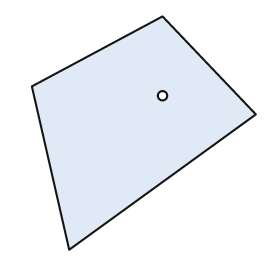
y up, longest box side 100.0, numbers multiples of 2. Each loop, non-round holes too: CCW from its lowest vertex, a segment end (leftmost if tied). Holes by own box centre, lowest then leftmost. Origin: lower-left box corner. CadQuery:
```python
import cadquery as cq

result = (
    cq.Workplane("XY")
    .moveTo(16.0, 0.0)
    .lineTo(96.0, 58.0)
    .lineTo(56.0, 100.0)
    .lineTo(0.0, 70.0)
    .close()
    .moveTo(56.0, 66.0)
    .circle(2.0)
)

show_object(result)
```